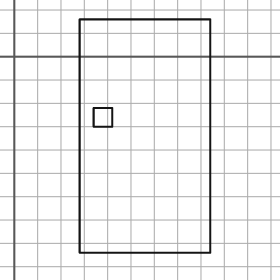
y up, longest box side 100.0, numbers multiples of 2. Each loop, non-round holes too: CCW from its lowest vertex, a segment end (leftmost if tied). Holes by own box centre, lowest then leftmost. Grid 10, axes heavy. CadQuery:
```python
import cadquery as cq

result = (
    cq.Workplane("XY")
    .moveTo(28.0, -84.0)
    .lineTo(84.0, -84.0)
    .lineTo(84.0, 16.0)
    .lineTo(28.0, 16.0)
    .close()
    .moveTo(34.0, -30.0)
    .lineTo(42.0, -30.0)
    .lineTo(42.0, -22.0)
    .lineTo(34.0, -22.0)
    .close()
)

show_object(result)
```